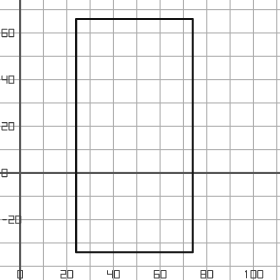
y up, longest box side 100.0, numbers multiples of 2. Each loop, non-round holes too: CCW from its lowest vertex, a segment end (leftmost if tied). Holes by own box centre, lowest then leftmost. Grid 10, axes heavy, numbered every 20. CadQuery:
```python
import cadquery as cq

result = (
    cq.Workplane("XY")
    .moveTo(24.0, -34.0)
    .lineTo(74.0, -34.0)
    .lineTo(74.0, 66.0)
    .lineTo(24.0, 66.0)
    .close()
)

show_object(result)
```